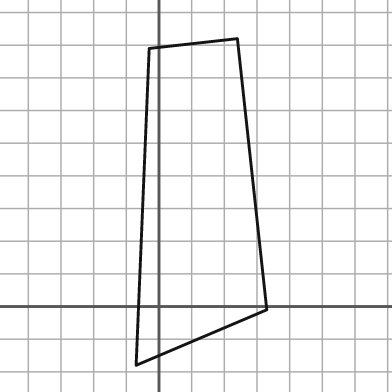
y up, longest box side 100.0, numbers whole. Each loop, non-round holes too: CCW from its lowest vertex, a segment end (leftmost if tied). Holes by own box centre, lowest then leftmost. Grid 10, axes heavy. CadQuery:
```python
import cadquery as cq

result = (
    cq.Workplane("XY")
    .moveTo(-7.0, -18.0)
    .lineTo(33.0, -1.0)
    .lineTo(24.0, 82.0)
    .lineTo(-3.0, 79.0)
    .close()
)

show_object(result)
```